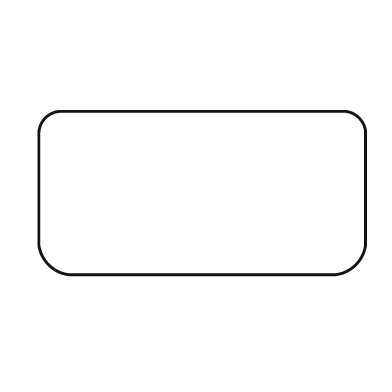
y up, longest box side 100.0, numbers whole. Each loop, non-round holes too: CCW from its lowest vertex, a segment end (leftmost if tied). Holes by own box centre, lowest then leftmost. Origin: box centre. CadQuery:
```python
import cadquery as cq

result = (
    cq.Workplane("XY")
    .moveTo(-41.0, -25.0)
    .lineTo(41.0, -25.0)
    .threePointArc((47.0, -22.0), (50.0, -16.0))
    .lineTo(50.0, 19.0)
    .threePointArc((48.0, 23.0), (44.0, 25.0))
    .lineTo(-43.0, 25.0)
    .threePointArc((-48.0, 23.0), (-50.0, 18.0))
    .lineTo(-50.0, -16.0)
    .threePointArc((-47.0, -22.0), (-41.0, -25.0))
    .close()
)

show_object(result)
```